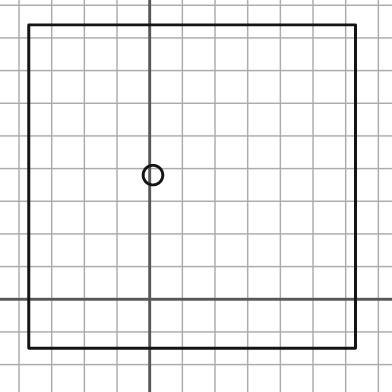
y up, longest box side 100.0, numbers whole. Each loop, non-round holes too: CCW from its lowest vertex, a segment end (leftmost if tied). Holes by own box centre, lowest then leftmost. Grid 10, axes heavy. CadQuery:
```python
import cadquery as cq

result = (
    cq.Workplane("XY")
    .moveTo(-37.0, -15.0)
    .lineTo(63.0, -15.0)
    .lineTo(63.0, 84.0)
    .lineTo(-37.0, 84.0)
    .close()
    .moveTo(1.0, 38.0)
    .circle(3.0)
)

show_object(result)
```